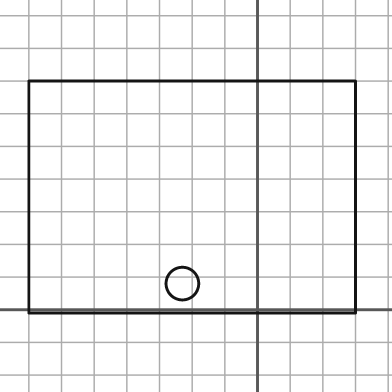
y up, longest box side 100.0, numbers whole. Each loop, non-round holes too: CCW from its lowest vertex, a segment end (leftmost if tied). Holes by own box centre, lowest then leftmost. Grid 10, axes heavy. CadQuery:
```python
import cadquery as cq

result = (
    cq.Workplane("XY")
    .moveTo(-70.0, -1.0)
    .lineTo(30.0, -1.0)
    .lineTo(30.0, 70.0)
    .lineTo(-70.0, 70.0)
    .close()
    .moveTo(-23.0, 8.0)
    .circle(5.0)
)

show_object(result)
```